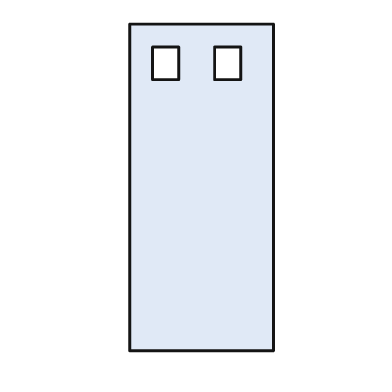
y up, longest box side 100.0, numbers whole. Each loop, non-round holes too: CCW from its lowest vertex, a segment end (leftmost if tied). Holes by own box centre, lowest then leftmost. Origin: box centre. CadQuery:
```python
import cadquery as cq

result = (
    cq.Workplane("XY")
    .moveTo(-22.0, -50.0)
    .lineTo(22.0, -50.0)
    .lineTo(22.0, 50.0)
    .lineTo(-22.0, 50.0)
    .close()
    .moveTo(-15.0, 33.0)
    .lineTo(-7.0, 33.0)
    .lineTo(-7.0, 43.0)
    .lineTo(-15.0, 43.0)
    .close()
    .moveTo(4.0, 33.0)
    .lineTo(12.0, 33.0)
    .lineTo(12.0, 43.0)
    .lineTo(4.0, 43.0)
    .close()
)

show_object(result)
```